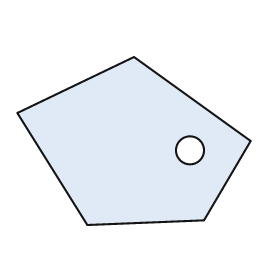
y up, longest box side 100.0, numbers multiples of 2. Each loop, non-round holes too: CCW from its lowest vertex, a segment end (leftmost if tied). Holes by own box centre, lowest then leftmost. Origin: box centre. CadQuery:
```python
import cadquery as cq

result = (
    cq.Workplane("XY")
    .moveTo(-20.0, -36.0)
    .lineTo(30.0, -34.0)
    .lineTo(50.0, 0.0)
    .lineTo(0.0, 36.0)
    .lineTo(-50.0, 12.0)
    .close()
    .moveTo(24.0, -4.0)
    .circle(6.0)
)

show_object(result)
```